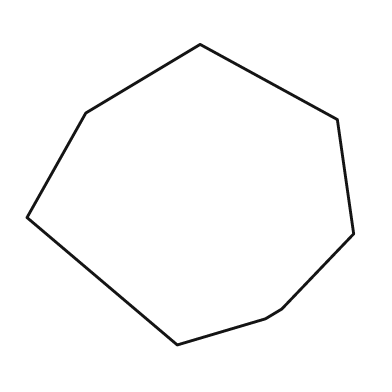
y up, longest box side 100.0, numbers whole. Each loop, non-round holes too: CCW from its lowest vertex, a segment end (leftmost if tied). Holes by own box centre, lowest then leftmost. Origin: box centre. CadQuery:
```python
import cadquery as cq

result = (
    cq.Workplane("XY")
    .moveTo(-4.0, -46.0)
    .lineTo(23.0, -38.0)
    .lineTo(28.0, -35.0)
    .lineTo(50.0, -12.0)
    .lineTo(45.0, 23.0)
    .lineTo(3.0, 46.0)
    .lineTo(-32.0, 25.0)
    .lineTo(-50.0, -7.0)
    .close()
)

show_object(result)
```